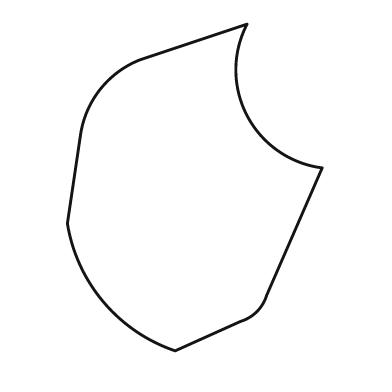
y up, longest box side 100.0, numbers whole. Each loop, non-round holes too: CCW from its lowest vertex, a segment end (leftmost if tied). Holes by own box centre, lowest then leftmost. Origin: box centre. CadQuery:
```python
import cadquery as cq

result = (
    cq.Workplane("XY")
    .moveTo(-6.0, -50.0)
    .lineTo(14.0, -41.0)
    .threePointArc((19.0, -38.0), (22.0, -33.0))
    .lineTo(39.0, 6.0)
    .threePointArc((16.0, 22.0), (16.0, 50.0))
    .lineTo(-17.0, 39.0)
    .threePointArc((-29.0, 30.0), (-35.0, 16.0))
    .lineTo(-39.0, -11.0)
    .threePointArc((-28.0, -35.0), (-6.0, -50.0))
    .close()
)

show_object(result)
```